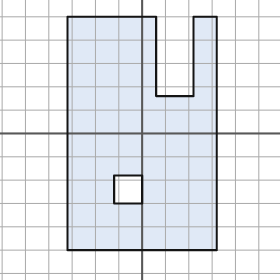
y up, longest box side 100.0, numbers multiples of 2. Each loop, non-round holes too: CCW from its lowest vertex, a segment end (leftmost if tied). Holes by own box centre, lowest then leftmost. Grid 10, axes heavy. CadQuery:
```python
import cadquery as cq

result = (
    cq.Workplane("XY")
    .moveTo(-32.0, -50.0)
    .lineTo(32.0, -50.0)
    .lineTo(32.0, 50.0)
    .lineTo(22.0, 50.0)
    .lineTo(22.0, 16.0)
    .lineTo(6.0, 16.0)
    .lineTo(6.0, 50.0)
    .lineTo(-32.0, 50.0)
    .close()
    .moveTo(-12.0, -30.0)
    .lineTo(0.0, -30.0)
    .lineTo(0.0, -18.0)
    .lineTo(-12.0, -18.0)
    .close()
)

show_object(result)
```